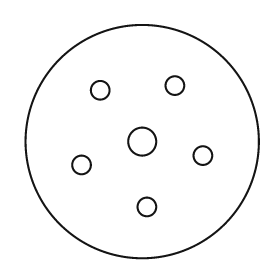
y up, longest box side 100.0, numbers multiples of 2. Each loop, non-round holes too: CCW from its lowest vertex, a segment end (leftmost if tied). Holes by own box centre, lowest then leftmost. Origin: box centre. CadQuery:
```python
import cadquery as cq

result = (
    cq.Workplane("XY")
    .moveTo(0.0, 0.0)
    .circle(50.0)
    .moveTo(2.0, -28.0)
    .circle(4.0)
    .moveTo(-26.0, -10.0)
    .circle(4.0)
    .moveTo(26.0, -6.0)
    .circle(4.0)
    .moveTo(0.0, 0.0)
    .circle(6.0)
    .moveTo(-18.0, 22.0)
    .circle(4.0)
    .moveTo(14.0, 24.0)
    .circle(4.0)
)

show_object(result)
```